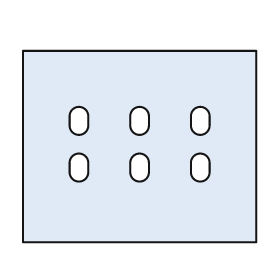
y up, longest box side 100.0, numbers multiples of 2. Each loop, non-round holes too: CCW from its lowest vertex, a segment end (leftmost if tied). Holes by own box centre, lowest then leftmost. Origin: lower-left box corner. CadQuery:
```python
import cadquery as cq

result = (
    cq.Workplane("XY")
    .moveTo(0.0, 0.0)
    .lineTo(100.0, 0.0)
    .lineTo(100.0, 82.0)
    .lineTo(0.0, 82.0)
    .close()
    .moveTo(20.0, 30.0)
    .threePointArc((24.0, 26.0), (28.0, 30.0))
    .lineTo(28.0, 34.0)
    .threePointArc((24.0, 38.0), (20.0, 34.0))
    .close()
    .moveTo(46.0, 30.0)
    .threePointArc((50.0, 26.0), (54.0, 30.0))
    .lineTo(54.0, 34.0)
    .threePointArc((50.0, 38.0), (46.0, 34.0))
    .close()
    .moveTo(72.0, 30.0)
    .threePointArc((76.0, 26.0), (80.0, 30.0))
    .lineTo(80.0, 34.0)
    .threePointArc((76.0, 38.0), (72.0, 34.0))
    .close()
    .moveTo(20.0, 50.0)
    .threePointArc((24.0, 46.0), (28.0, 50.0))
    .lineTo(28.0, 54.0)
    .threePointArc((24.0, 58.0), (20.0, 54.0))
    .close()
    .moveTo(46.0, 50.0)
    .threePointArc((50.0, 46.0), (54.0, 50.0))
    .lineTo(54.0, 54.0)
    .threePointArc((50.0, 58.0), (46.0, 54.0))
    .close()
    .moveTo(72.0, 50.0)
    .threePointArc((76.0, 46.0), (80.0, 50.0))
    .lineTo(80.0, 54.0)
    .threePointArc((76.0, 58.0), (72.0, 54.0))
    .close()
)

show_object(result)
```